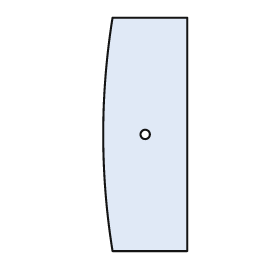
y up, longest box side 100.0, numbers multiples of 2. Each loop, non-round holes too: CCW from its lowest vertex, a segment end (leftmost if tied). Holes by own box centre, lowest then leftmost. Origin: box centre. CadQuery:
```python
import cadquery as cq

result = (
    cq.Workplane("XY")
    .moveTo(-14.0, -50.0)
    .lineTo(18.0, -50.0)
    .lineTo(18.0, 50.0)
    .lineTo(-14.0, 50.0)
    .threePointArc((-18.0, 0.0), (-14.0, -50.0))
    .close()
    .moveTo(0.0, 0.0)
    .circle(2.0)
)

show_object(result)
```